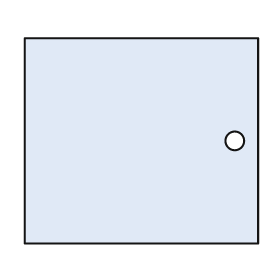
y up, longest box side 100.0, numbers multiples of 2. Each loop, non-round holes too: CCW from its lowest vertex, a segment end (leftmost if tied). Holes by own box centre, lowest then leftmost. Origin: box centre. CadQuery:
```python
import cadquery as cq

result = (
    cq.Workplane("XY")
    .moveTo(-50.0, -44.0)
    .lineTo(50.0, -44.0)
    .lineTo(50.0, 44.0)
    .lineTo(-50.0, 44.0)
    .close()
    .moveTo(40.0, 0.0)
    .circle(4.0)
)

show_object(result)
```